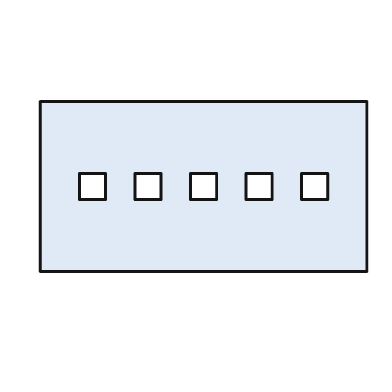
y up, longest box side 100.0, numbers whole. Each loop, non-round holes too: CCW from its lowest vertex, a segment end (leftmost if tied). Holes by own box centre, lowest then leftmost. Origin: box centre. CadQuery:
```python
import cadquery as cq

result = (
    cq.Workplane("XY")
    .moveTo(-50.0, -26.0)
    .lineTo(50.0, -26.0)
    .lineTo(50.0, 26.0)
    .lineTo(-50.0, 26.0)
    .close()
    .moveTo(-38.0, -4.0)
    .lineTo(-30.0, -4.0)
    .lineTo(-30.0, 4.0)
    .lineTo(-38.0, 4.0)
    .close()
    .moveTo(-21.0, -4.0)
    .lineTo(-13.0, -4.0)
    .lineTo(-13.0, 4.0)
    .lineTo(-21.0, 4.0)
    .close()
    .moveTo(-4.0, -4.0)
    .lineTo(4.0, -4.0)
    .lineTo(4.0, 4.0)
    .lineTo(-4.0, 4.0)
    .close()
    .moveTo(13.0, -4.0)
    .lineTo(21.0, -4.0)
    .lineTo(21.0, 4.0)
    .lineTo(13.0, 4.0)
    .close()
    .moveTo(30.0, -4.0)
    .lineTo(38.0, -4.0)
    .lineTo(38.0, 4.0)
    .lineTo(30.0, 4.0)
    .close()
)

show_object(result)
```